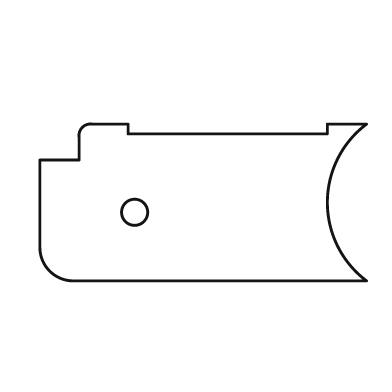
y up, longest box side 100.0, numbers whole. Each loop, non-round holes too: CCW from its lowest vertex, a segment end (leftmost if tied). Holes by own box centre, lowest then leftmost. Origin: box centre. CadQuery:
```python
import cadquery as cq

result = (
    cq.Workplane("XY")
    .moveTo(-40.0, -24.0)
    .lineTo(50.0, -24.0)
    .threePointArc((38.0, 0.0), (50.0, 24.0))
    .lineTo(38.0, 24.0)
    .lineTo(38.0, 21.0)
    .lineTo(-23.0, 21.0)
    .lineTo(-23.0, 24.0)
    .lineTo(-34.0, 24.0)
    .threePointArc((-37.0, 23.0), (-38.0, 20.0))
    .lineTo(-38.0, 13.0)
    .lineTo(-50.0, 13.0)
    .lineTo(-50.0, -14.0)
    .threePointArc((-47.0, -21.0), (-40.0, -24.0))
    .close()
    .moveTo(-21.0, -3.0)
    .circle(4.0)
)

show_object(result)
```